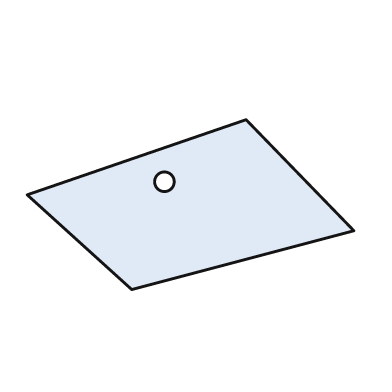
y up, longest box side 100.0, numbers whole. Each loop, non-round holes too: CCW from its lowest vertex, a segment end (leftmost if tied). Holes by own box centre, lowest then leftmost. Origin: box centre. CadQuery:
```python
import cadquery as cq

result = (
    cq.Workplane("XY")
    .moveTo(-18.0, -26.0)
    .lineTo(50.0, -8.0)
    .lineTo(17.0, 26.0)
    .lineTo(-50.0, 3.0)
    .close()
    .moveTo(-8.0, 7.0)
    .circle(3.0)
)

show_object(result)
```